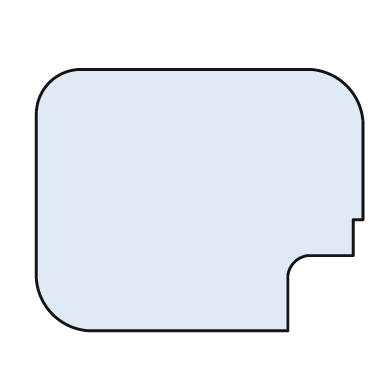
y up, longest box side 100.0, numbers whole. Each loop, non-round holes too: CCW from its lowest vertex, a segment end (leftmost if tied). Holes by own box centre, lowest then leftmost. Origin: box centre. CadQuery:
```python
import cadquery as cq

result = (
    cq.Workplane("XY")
    .moveTo(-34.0, -40.0)
    .lineTo(27.0, -40.0)
    .lineTo(27.0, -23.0)
    .threePointArc((29.0, -19.0), (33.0, -17.0))
    .lineTo(47.0, -17.0)
    .lineTo(47.0, -6.0)
    .lineTo(50.0, -6.0)
    .lineTo(50.0, 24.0)
    .threePointArc((45.0, 35.0), (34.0, 40.0))
    .lineTo(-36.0, 40.0)
    .threePointArc((-46.0, 36.0), (-50.0, 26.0))
    .lineTo(-50.0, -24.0)
    .threePointArc((-45.0, -35.0), (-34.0, -40.0))
    .close()
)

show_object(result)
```